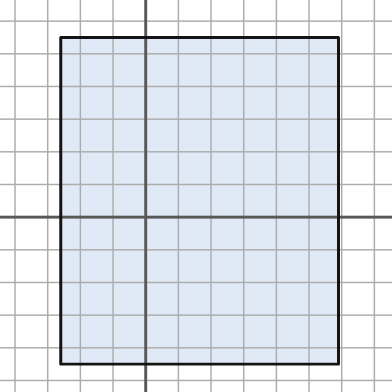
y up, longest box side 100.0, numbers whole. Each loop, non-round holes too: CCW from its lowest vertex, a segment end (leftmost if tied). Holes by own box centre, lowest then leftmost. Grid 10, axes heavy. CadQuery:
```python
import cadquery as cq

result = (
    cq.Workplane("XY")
    .moveTo(-26.0, -45.0)
    .lineTo(59.0, -45.0)
    .lineTo(59.0, 55.0)
    .lineTo(-26.0, 55.0)
    .close()
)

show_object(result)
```